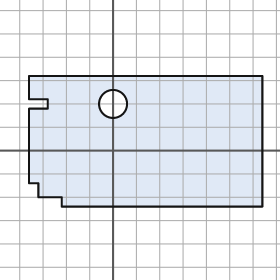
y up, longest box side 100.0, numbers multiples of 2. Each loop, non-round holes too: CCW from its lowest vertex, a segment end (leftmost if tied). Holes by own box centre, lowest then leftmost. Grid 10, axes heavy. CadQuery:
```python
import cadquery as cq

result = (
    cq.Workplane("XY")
    .moveTo(-22.0, -24.0)
    .lineTo(64.0, -24.0)
    .lineTo(64.0, 32.0)
    .lineTo(-36.0, 32.0)
    .lineTo(-36.0, 22.0)
    .lineTo(-28.0, 22.0)
    .lineTo(-28.0, 18.0)
    .lineTo(-36.0, 18.0)
    .lineTo(-36.0, -14.0)
    .lineTo(-32.0, -14.0)
    .lineTo(-32.0, -20.0)
    .lineTo(-22.0, -20.0)
    .close()
    .moveTo(0.0, 20.0)
    .circle(6.0)
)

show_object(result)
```